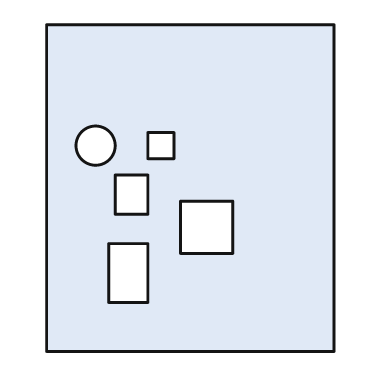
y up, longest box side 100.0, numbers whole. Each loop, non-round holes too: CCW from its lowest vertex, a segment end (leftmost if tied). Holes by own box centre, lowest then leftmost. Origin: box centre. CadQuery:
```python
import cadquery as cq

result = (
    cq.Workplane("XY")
    .moveTo(-44.0, -50.0)
    .lineTo(44.0, -50.0)
    .lineTo(44.0, 50.0)
    .lineTo(-44.0, 50.0)
    .close()
    .moveTo(-25.0, -35.0)
    .lineTo(-13.0, -35.0)
    .lineTo(-13.0, -17.0)
    .lineTo(-25.0, -17.0)
    .close()
    .moveTo(-3.0, -20.0)
    .lineTo(13.0, -20.0)
    .lineTo(13.0, -4.0)
    .lineTo(-3.0, -4.0)
    .close()
    .moveTo(-23.0, -8.0)
    .lineTo(-13.0, -8.0)
    .lineTo(-13.0, 4.0)
    .lineTo(-23.0, 4.0)
    .close()
    .moveTo(-29.0, 13.0)
    .circle(6.0)
    .moveTo(-13.0, 9.0)
    .lineTo(-5.0, 9.0)
    .lineTo(-5.0, 17.0)
    .lineTo(-13.0, 17.0)
    .close()
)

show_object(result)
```